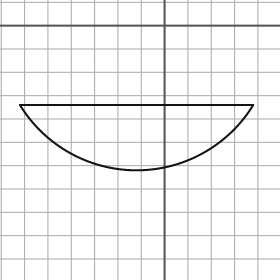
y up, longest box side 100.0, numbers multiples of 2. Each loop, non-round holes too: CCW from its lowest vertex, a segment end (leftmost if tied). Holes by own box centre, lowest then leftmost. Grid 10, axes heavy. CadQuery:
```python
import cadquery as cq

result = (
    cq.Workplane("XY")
    .moveTo(-62.0, -34.0)
    .threePointArc((-12.0, -62.0), (38.0, -34.0))
    .close()
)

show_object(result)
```